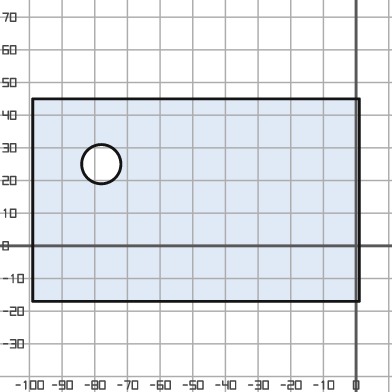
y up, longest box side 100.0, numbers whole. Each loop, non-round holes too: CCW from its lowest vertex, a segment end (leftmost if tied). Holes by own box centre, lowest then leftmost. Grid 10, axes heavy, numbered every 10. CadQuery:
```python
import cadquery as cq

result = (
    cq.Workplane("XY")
    .moveTo(-99.0, -17.0)
    .lineTo(1.0, -17.0)
    .lineTo(1.0, 45.0)
    .lineTo(-99.0, 45.0)
    .close()
    .moveTo(-78.0, 25.0)
    .circle(6.0)
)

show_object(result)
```